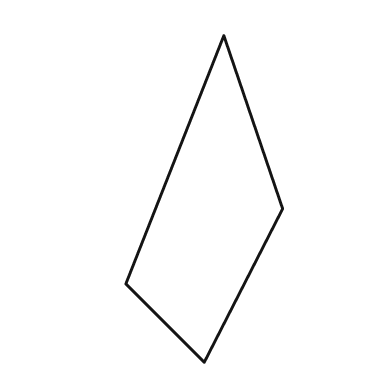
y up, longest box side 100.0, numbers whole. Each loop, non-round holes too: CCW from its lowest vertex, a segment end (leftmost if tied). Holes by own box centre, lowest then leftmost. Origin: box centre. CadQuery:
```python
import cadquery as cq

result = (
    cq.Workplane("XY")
    .moveTo(0.0, -50.0)
    .lineTo(24.0, -3.0)
    .lineTo(6.0, 50.0)
    .lineTo(-24.0, -26.0)
    .close()
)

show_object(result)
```